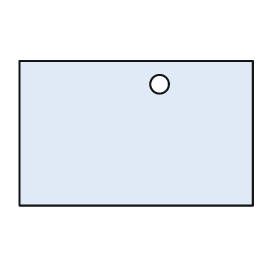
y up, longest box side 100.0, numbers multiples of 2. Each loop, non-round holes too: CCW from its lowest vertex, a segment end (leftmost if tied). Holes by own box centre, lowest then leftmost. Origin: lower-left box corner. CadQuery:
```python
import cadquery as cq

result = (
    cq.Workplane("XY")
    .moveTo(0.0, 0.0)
    .lineTo(100.0, 0.0)
    .lineTo(100.0, 62.0)
    .lineTo(0.0, 62.0)
    .close()
    .moveTo(60.0, 52.0)
    .circle(4.0)
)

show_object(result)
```